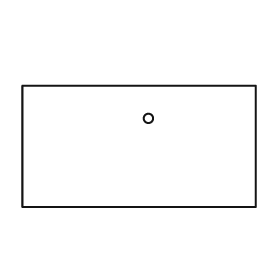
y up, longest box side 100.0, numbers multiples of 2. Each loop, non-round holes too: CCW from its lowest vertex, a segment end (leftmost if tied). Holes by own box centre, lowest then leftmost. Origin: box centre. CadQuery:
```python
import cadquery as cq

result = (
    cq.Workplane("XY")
    .moveTo(-50.0, -26.0)
    .lineTo(50.0, -26.0)
    .lineTo(50.0, 26.0)
    .lineTo(-50.0, 26.0)
    .close()
    .moveTo(4.0, 12.0)
    .circle(2.0)
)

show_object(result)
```